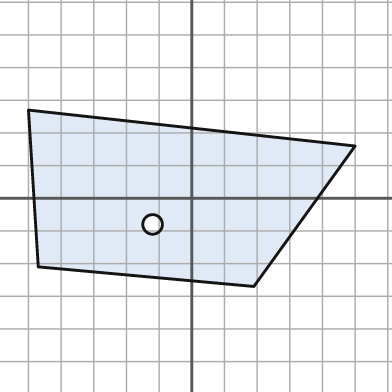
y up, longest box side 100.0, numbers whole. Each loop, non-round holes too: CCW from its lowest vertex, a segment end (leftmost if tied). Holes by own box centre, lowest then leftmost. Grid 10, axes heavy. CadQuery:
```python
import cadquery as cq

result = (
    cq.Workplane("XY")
    .moveTo(19.0, -27.0)
    .lineTo(50.0, 16.0)
    .lineTo(-50.0, 27.0)
    .lineTo(-47.0, -21.0)
    .close()
    .moveTo(-12.0, -8.0)
    .circle(3.0)
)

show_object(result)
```